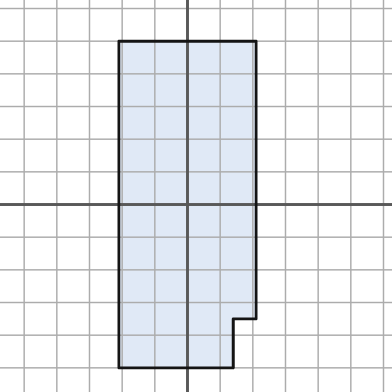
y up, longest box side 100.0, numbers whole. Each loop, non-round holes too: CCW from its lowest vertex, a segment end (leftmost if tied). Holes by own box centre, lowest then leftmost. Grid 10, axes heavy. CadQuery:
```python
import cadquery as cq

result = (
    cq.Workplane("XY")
    .moveTo(-21.0, -50.0)
    .lineTo(14.0, -50.0)
    .lineTo(14.0, -35.0)
    .lineTo(21.0, -35.0)
    .lineTo(21.0, 50.0)
    .lineTo(-21.0, 50.0)
    .close()
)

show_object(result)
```